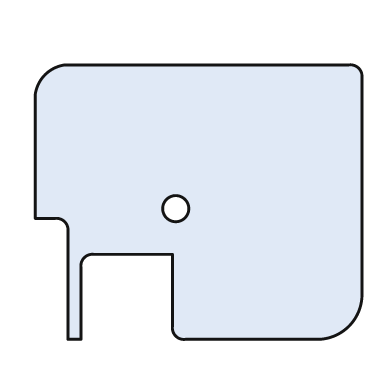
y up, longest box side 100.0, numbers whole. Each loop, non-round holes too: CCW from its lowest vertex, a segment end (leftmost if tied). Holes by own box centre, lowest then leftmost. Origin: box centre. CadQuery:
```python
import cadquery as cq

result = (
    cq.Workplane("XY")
    .moveTo(-40.0, -42.0)
    .lineTo(-36.0, -42.0)
    .lineTo(-36.0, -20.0)
    .threePointArc((-35.0, -17.0), (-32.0, -16.0))
    .lineTo(-8.0, -16.0)
    .lineTo(-8.0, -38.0)
    .threePointArc((-7.0, -41.0), (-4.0, -42.0))
    .lineTo(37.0, -42.0)
    .threePointArc((46.0, -38.0), (50.0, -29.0))
    .lineTo(50.0, 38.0)
    .threePointArc((49.0, 41.0), (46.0, 42.0))
    .lineTo(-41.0, 42.0)
    .threePointArc((-47.0, 39.0), (-50.0, 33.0))
    .lineTo(-50.0, -5.0)
    .lineTo(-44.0, -5.0)
    .threePointArc((-41.0, -6.0), (-40.0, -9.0))
    .close()
    .moveTo(-7.0, -2.0)
    .circle(4.0)
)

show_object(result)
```